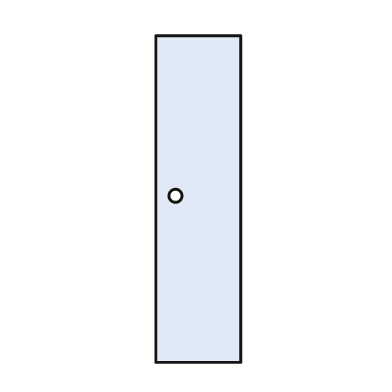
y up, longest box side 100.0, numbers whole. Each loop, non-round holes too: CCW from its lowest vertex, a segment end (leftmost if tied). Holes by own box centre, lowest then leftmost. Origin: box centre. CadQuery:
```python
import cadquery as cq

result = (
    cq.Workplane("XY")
    .moveTo(-13.0, -50.0)
    .lineTo(13.0, -50.0)
    .lineTo(13.0, 50.0)
    .lineTo(-13.0, 50.0)
    .close()
    .moveTo(-7.0, 1.0)
    .circle(2.0)
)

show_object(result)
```